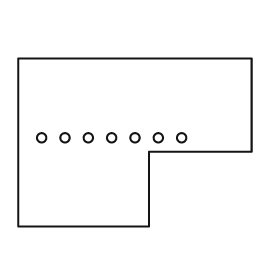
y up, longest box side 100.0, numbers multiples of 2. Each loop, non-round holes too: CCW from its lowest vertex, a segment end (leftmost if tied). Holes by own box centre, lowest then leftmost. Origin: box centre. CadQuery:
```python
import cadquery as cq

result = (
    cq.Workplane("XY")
    .moveTo(-50.0, -36.0)
    .lineTo(6.0, -36.0)
    .lineTo(6.0, -4.0)
    .lineTo(50.0, -4.0)
    .lineTo(50.0, 36.0)
    .lineTo(-50.0, 36.0)
    .close()
    .moveTo(-40.0, 2.0)
    .circle(2.0)
    .moveTo(-30.0, 2.0)
    .circle(2.0)
    .moveTo(-20.0, 2.0)
    .circle(2.0)
    .moveTo(-10.0, 2.0)
    .circle(2.0)
    .moveTo(0.0, 2.0)
    .circle(2.0)
    .moveTo(10.0, 2.0)
    .circle(2.0)
    .moveTo(20.0, 2.0)
    .circle(2.0)
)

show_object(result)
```